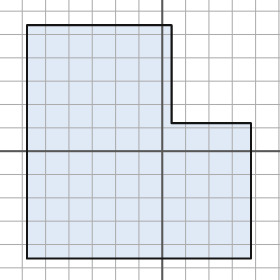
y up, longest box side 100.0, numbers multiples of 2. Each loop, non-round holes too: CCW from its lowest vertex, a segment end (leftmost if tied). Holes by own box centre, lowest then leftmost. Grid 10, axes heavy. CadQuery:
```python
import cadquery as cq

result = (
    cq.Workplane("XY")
    .moveTo(-58.0, -46.0)
    .lineTo(38.0, -46.0)
    .lineTo(38.0, 12.0)
    .lineTo(4.0, 12.0)
    .lineTo(4.0, 54.0)
    .lineTo(-58.0, 54.0)
    .close()
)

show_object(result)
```